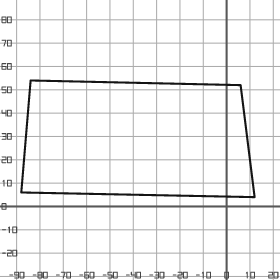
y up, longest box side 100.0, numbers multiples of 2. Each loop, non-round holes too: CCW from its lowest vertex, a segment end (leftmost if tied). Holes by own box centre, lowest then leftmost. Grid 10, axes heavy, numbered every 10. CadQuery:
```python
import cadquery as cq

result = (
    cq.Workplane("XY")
    .moveTo(12.0, 4.0)
    .lineTo(6.0, 52.0)
    .lineTo(-84.0, 54.0)
    .lineTo(-88.0, 6.0)
    .close()
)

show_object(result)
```